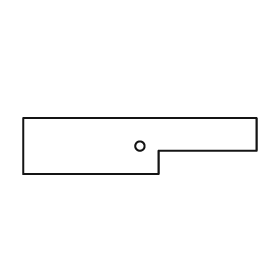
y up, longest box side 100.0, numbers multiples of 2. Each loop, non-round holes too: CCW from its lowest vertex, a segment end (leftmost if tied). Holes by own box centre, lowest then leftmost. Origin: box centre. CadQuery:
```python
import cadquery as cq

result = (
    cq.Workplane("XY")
    .moveTo(-50.0, -12.0)
    .lineTo(8.0, -12.0)
    .lineTo(8.0, -2.0)
    .lineTo(50.0, -2.0)
    .lineTo(50.0, 12.0)
    .lineTo(-50.0, 12.0)
    .close()
    .moveTo(0.0, 0.0)
    .circle(2.0)
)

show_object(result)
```